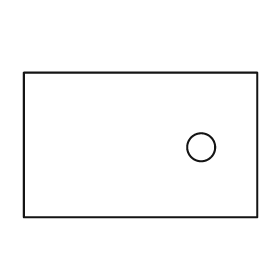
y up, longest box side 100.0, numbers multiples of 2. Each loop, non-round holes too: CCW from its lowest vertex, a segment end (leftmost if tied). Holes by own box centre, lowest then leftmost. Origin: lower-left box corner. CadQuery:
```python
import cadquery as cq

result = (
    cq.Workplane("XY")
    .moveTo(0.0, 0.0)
    .lineTo(100.0, 0.0)
    .lineTo(100.0, 62.0)
    .lineTo(0.0, 62.0)
    .close()
    .moveTo(76.0, 30.0)
    .circle(6.0)
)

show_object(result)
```